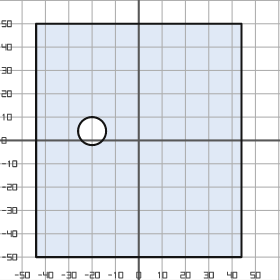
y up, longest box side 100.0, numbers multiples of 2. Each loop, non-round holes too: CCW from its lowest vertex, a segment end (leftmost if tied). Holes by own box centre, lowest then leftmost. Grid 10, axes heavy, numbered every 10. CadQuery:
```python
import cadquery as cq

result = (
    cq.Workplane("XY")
    .moveTo(-44.0, -50.0)
    .lineTo(44.0, -50.0)
    .lineTo(44.0, 50.0)
    .lineTo(-44.0, 50.0)
    .close()
    .moveTo(-20.0, 4.0)
    .circle(6.0)
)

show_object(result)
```